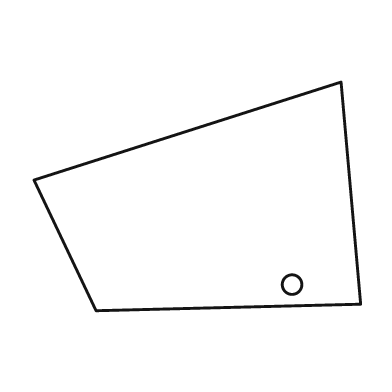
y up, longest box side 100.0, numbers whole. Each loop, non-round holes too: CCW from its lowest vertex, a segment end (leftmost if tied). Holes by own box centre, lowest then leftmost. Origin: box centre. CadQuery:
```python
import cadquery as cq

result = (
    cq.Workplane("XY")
    .moveTo(-31.0, -35.0)
    .lineTo(50.0, -33.0)
    .lineTo(44.0, 35.0)
    .lineTo(-50.0, 5.0)
    .close()
    .moveTo(29.0, -27.0)
    .circle(3.0)
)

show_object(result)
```